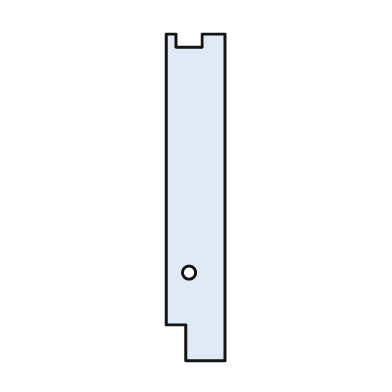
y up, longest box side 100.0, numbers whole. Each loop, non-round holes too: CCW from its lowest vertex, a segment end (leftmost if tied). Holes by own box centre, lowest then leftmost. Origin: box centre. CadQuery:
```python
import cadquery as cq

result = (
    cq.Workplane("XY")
    .moveTo(-3.0, -50.0)
    .lineTo(9.0, -50.0)
    .lineTo(9.0, 50.0)
    .lineTo(2.0, 50.0)
    .lineTo(2.0, 46.0)
    .lineTo(-6.0, 46.0)
    .lineTo(-6.0, 50.0)
    .lineTo(-9.0, 50.0)
    .lineTo(-9.0, -39.0)
    .lineTo(-3.0, -39.0)
    .close()
    .moveTo(-2.0, -23.0)
    .circle(2.0)
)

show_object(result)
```